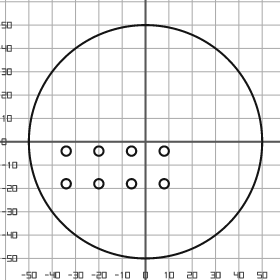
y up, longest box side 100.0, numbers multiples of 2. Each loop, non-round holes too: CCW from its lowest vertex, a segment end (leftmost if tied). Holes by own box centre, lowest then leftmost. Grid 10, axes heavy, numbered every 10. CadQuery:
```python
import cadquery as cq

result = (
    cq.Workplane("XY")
    .moveTo(0.0, 0.0)
    .circle(50.0)
    .moveTo(-34.0, -18.0)
    .circle(2.0)
    .moveTo(-20.0, -18.0)
    .circle(2.0)
    .moveTo(-6.0, -18.0)
    .circle(2.0)
    .moveTo(8.0, -18.0)
    .circle(2.0)
    .moveTo(-34.0, -4.0)
    .circle(2.0)
    .moveTo(-20.0, -4.0)
    .circle(2.0)
    .moveTo(-6.0, -4.0)
    .circle(2.0)
    .moveTo(8.0, -4.0)
    .circle(2.0)
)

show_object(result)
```